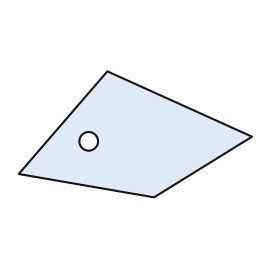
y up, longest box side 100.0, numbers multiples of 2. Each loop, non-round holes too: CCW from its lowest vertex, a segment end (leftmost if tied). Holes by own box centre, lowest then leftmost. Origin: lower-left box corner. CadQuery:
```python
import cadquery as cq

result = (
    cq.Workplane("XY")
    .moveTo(58.0, 0.0)
    .lineTo(100.0, 26.0)
    .lineTo(38.0, 54.0)
    .lineTo(0.0, 10.0)
    .close()
    .moveTo(30.0, 24.0)
    .circle(4.0)
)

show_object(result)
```